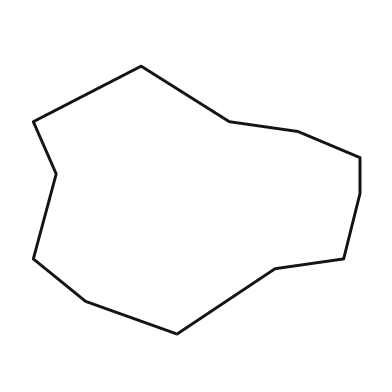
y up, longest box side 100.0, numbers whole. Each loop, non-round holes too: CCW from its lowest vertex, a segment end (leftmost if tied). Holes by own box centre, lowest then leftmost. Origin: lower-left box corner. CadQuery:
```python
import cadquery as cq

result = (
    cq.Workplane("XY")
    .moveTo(44.0, 0.0)
    .lineTo(74.0, 20.0)
    .lineTo(95.0, 23.0)
    .lineTo(100.0, 43.0)
    .lineTo(100.0, 54.0)
    .lineTo(81.0, 62.0)
    .lineTo(60.0, 65.0)
    .lineTo(33.0, 82.0)
    .lineTo(0.0, 65.0)
    .lineTo(7.0, 49.0)
    .lineTo(0.0, 23.0)
    .lineTo(16.0, 10.0)
    .close()
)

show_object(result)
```